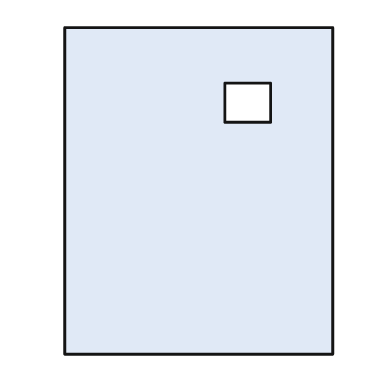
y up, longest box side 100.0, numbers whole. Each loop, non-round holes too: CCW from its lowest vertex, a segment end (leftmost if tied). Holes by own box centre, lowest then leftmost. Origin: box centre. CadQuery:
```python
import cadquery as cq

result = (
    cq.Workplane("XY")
    .moveTo(-41.0, -50.0)
    .lineTo(41.0, -50.0)
    .lineTo(41.0, 50.0)
    .lineTo(-41.0, 50.0)
    .close()
    .moveTo(8.0, 21.0)
    .lineTo(22.0, 21.0)
    .lineTo(22.0, 33.0)
    .lineTo(8.0, 33.0)
    .close()
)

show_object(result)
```